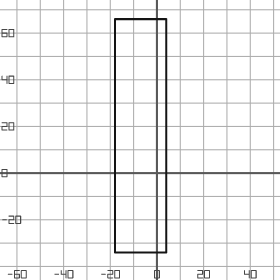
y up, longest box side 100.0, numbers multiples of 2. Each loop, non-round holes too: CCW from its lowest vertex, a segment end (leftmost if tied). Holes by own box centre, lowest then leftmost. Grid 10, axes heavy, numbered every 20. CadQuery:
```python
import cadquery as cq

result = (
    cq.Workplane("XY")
    .moveTo(-18.0, -34.0)
    .lineTo(4.0, -34.0)
    .lineTo(4.0, 66.0)
    .lineTo(-18.0, 66.0)
    .close()
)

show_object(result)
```